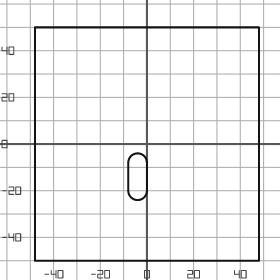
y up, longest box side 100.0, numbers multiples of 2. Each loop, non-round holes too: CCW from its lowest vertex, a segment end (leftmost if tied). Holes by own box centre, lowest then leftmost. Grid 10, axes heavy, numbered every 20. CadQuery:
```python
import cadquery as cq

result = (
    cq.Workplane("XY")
    .moveTo(-48.0, -50.0)
    .lineTo(48.0, -50.0)
    .lineTo(48.0, 50.0)
    .lineTo(-48.0, 50.0)
    .close()
    .moveTo(-8.0, -20.0)
    .threePointArc((-4.0, -24.0), (0.0, -20.0))
    .lineTo(0.0, -8.0)
    .threePointArc((-4.0, -4.0), (-8.0, -8.0))
    .close()
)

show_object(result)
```